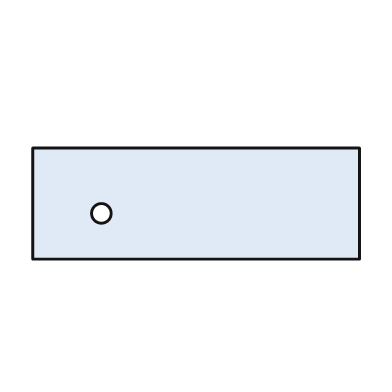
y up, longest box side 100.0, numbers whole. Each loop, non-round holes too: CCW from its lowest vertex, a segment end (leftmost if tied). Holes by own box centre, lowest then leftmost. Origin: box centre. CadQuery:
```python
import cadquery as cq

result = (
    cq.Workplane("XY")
    .moveTo(-50.0, -17.0)
    .lineTo(50.0, -17.0)
    .lineTo(50.0, 17.0)
    .lineTo(-50.0, 17.0)
    .close()
    .moveTo(-29.0, -3.0)
    .circle(3.0)
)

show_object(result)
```